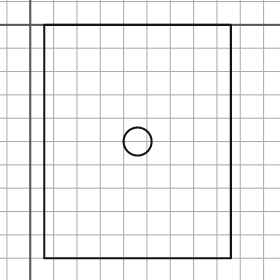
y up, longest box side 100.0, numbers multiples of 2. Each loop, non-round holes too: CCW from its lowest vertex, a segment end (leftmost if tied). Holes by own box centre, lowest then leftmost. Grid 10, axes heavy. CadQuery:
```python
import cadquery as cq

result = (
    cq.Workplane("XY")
    .moveTo(6.0, -100.0)
    .lineTo(86.0, -100.0)
    .lineTo(86.0, 0.0)
    .lineTo(6.0, 0.0)
    .close()
    .moveTo(46.0, -50.0)
    .circle(6.0)
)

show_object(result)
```